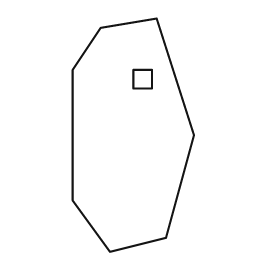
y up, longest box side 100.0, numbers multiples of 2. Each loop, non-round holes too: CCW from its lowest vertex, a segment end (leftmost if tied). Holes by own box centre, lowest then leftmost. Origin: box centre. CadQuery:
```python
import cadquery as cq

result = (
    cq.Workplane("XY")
    .moveTo(-10.0, -50.0)
    .lineTo(14.0, -44.0)
    .lineTo(26.0, 0.0)
    .lineTo(10.0, 50.0)
    .lineTo(-14.0, 46.0)
    .lineTo(-26.0, 28.0)
    .lineTo(-26.0, -28.0)
    .close()
    .moveTo(0.0, 20.0)
    .lineTo(8.0, 20.0)
    .lineTo(8.0, 28.0)
    .lineTo(0.0, 28.0)
    .close()
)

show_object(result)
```